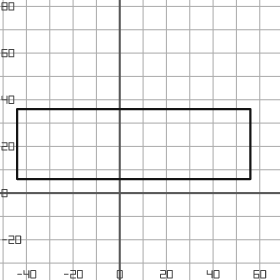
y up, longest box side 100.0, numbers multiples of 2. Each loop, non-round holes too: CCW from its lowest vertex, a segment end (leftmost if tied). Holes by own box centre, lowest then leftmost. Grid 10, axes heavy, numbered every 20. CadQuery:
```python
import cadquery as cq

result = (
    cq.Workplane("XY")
    .moveTo(-44.0, 6.0)
    .lineTo(56.0, 6.0)
    .lineTo(56.0, 36.0)
    .lineTo(-44.0, 36.0)
    .close()
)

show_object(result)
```